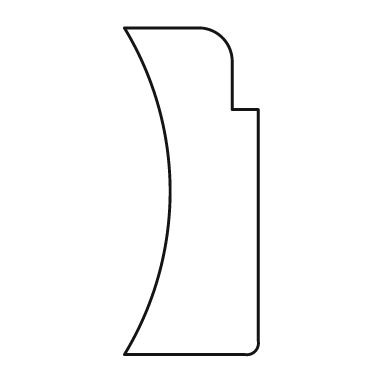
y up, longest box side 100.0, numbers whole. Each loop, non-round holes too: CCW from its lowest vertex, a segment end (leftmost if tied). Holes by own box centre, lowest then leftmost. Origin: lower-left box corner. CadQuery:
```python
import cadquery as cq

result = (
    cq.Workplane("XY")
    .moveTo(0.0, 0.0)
    .lineTo(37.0, 0.0)
    .threePointArc((40.0, 1.0), (41.0, 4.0))
    .lineTo(41.0, 75.0)
    .lineTo(33.0, 75.0)
    .lineTo(33.0, 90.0)
    .threePointArc((30.0, 97.0), (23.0, 100.0))
    .lineTo(0.0, 100.0)
    .threePointArc((14.0, 50.0), (0.0, 0.0))
    .close()
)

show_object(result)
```